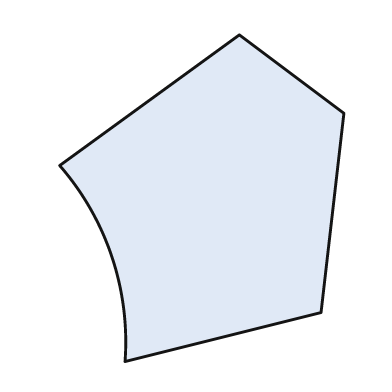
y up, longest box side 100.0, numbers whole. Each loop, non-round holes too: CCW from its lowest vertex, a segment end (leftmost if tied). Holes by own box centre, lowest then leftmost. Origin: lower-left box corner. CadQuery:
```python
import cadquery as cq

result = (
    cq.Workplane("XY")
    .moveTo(20.0, 0.0)
    .lineTo(80.0, 15.0)
    .lineTo(87.0, 76.0)
    .lineTo(55.0, 100.0)
    .lineTo(0.0, 60.0)
    .threePointArc((16.0, 32.0), (20.0, 0.0))
    .close()
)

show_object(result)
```